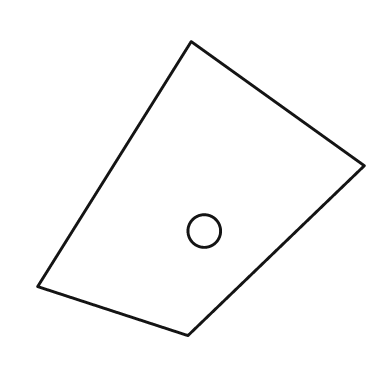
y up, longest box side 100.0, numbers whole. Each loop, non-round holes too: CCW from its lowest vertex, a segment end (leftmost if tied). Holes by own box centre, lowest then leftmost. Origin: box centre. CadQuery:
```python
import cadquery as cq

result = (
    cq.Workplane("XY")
    .moveTo(-4.0, -45.0)
    .lineTo(50.0, 7.0)
    .lineTo(-3.0, 45.0)
    .lineTo(-50.0, -30.0)
    .close()
    .moveTo(1.0, -13.0)
    .circle(5.0)
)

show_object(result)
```